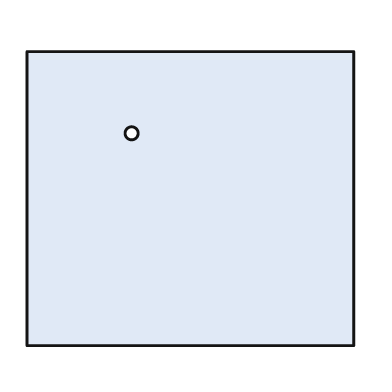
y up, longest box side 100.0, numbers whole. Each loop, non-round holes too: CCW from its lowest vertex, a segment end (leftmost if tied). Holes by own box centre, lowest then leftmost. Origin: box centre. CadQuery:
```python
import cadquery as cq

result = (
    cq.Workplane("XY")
    .moveTo(-50.0, -45.0)
    .lineTo(50.0, -45.0)
    .lineTo(50.0, 45.0)
    .lineTo(-50.0, 45.0)
    .close()
    .moveTo(-18.0, 20.0)
    .circle(2.0)
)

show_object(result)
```